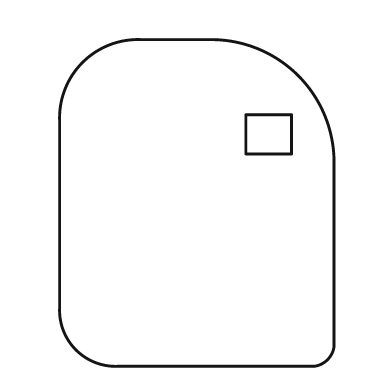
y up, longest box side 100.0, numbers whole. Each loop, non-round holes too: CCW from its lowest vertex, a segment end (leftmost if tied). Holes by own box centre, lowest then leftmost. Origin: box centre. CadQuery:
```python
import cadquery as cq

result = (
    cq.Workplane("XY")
    .moveTo(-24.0, -50.0)
    .lineTo(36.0, -50.0)
    .threePointArc((40.0, -48.0), (42.0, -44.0))
    .lineTo(42.0, 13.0)
    .threePointArc((31.0, 39.0), (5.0, 50.0))
    .lineTo(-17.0, 50.0)
    .threePointArc((-35.0, 43.0), (-42.0, 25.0))
    .lineTo(-42.0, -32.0)
    .threePointArc((-37.0, -45.0), (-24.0, -50.0))
    .close()
    .moveTo(15.0, 15.0)
    .lineTo(29.0, 15.0)
    .lineTo(29.0, 27.0)
    .lineTo(15.0, 27.0)
    .close()
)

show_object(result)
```